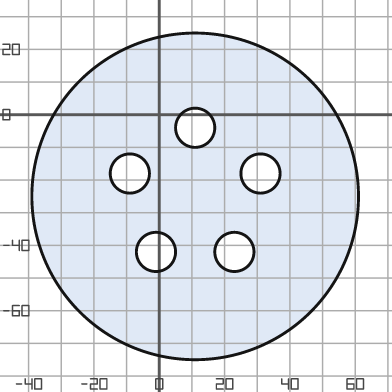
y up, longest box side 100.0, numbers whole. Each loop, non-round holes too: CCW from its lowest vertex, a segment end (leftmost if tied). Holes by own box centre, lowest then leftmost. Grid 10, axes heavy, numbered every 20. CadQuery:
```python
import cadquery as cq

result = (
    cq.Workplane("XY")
    .moveTo(11.0, -25.0)
    .circle(50.0)
    .moveTo(-1.0, -42.0)
    .circle(6.0)
    .moveTo(23.0, -42.0)
    .circle(6.0)
    .moveTo(-9.0, -18.0)
    .circle(6.0)
    .moveTo(31.0, -18.0)
    .circle(6.0)
    .moveTo(11.0, -4.0)
    .circle(6.0)
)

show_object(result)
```